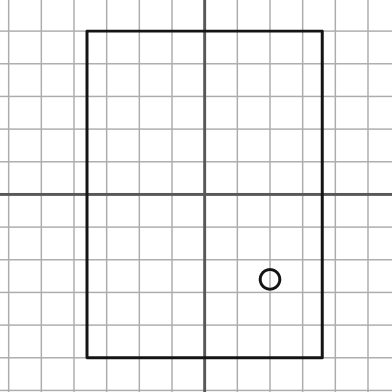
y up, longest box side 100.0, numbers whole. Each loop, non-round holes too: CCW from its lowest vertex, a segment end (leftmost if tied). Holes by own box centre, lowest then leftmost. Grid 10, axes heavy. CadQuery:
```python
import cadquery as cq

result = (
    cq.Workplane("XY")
    .moveTo(-36.0, -50.0)
    .lineTo(36.0, -50.0)
    .lineTo(36.0, 50.0)
    .lineTo(-36.0, 50.0)
    .close()
    .moveTo(20.0, -26.0)
    .circle(3.0)
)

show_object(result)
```